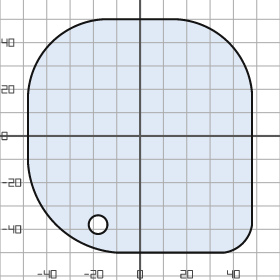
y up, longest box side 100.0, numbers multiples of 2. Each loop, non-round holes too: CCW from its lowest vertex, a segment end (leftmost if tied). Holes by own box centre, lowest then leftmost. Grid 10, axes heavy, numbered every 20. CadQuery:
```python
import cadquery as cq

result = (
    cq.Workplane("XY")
    .moveTo(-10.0, -50.0)
    .lineTo(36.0, -50.0)
    .threePointArc((44.0, -46.0), (48.0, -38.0))
    .lineTo(48.0, 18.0)
    .threePointArc((38.0, 40.0), (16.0, 50.0))
    .lineTo(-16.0, 50.0)
    .threePointArc((-38.0, 40.0), (-48.0, 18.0))
    .lineTo(-48.0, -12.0)
    .threePointArc((-36.0, -38.0), (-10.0, -50.0))
    .close()
    .moveTo(-18.0, -38.0)
    .circle(4.0)
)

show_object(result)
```